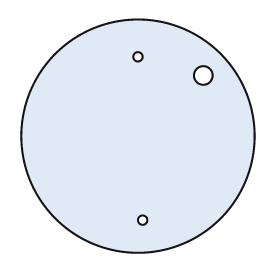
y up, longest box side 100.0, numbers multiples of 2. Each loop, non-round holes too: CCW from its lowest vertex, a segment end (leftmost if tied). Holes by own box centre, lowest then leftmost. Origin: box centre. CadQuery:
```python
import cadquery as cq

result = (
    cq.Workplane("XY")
    .moveTo(0.0, 0.0)
    .circle(50.0)
    .moveTo(2.0, -36.0)
    .circle(2.0)
    .moveTo(28.0, 26.0)
    .circle(4.0)
    .moveTo(0.0, 34.0)
    .circle(2.0)
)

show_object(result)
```